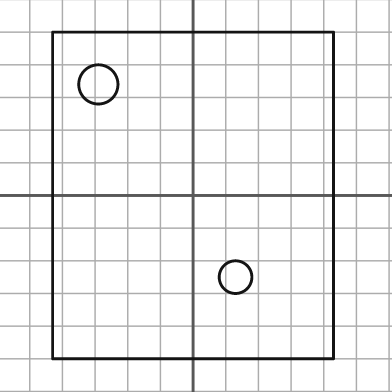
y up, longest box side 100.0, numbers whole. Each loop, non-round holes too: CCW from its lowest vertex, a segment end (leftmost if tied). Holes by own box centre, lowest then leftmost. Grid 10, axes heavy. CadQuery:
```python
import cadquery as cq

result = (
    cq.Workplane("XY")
    .moveTo(-43.0, -50.0)
    .lineTo(43.0, -50.0)
    .lineTo(43.0, 50.0)
    .lineTo(-43.0, 50.0)
    .close()
    .moveTo(13.0, -25.0)
    .circle(5.0)
    .moveTo(-29.0, 34.0)
    .circle(6.0)
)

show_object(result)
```